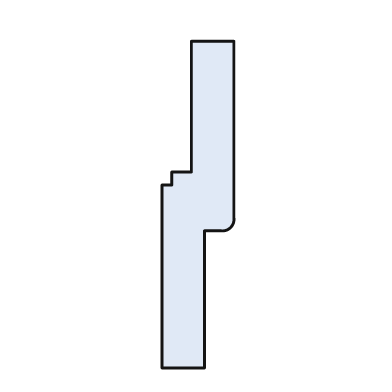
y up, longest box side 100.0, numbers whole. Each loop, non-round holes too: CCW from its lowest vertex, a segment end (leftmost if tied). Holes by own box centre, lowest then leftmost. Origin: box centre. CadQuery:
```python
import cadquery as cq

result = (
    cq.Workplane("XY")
    .moveTo(-11.0, -50.0)
    .lineTo(2.0, -50.0)
    .lineTo(2.0, -8.0)
    .lineTo(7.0, -8.0)
    .threePointArc((10.0, -7.0), (11.0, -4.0))
    .lineTo(11.0, 50.0)
    .lineTo(-2.0, 50.0)
    .lineTo(-2.0, 10.0)
    .lineTo(-8.0, 10.0)
    .lineTo(-8.0, 6.0)
    .lineTo(-11.0, 6.0)
    .close()
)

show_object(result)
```